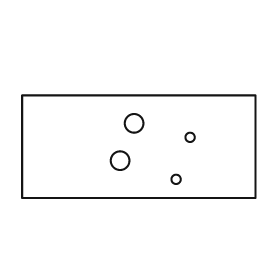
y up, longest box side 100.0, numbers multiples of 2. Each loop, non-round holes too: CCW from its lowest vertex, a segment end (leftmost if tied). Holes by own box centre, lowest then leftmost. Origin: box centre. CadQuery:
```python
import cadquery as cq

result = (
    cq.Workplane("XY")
    .moveTo(-50.0, -22.0)
    .lineTo(50.0, -22.0)
    .lineTo(50.0, 22.0)
    .lineTo(-50.0, 22.0)
    .close()
    .moveTo(16.0, -14.0)
    .circle(2.0)
    .moveTo(-8.0, -6.0)
    .circle(4.0)
    .moveTo(22.0, 4.0)
    .circle(2.0)
    .moveTo(-2.0, 10.0)
    .circle(4.0)
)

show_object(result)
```